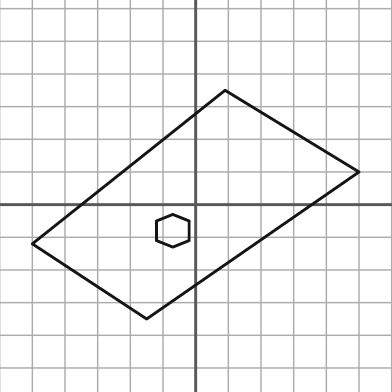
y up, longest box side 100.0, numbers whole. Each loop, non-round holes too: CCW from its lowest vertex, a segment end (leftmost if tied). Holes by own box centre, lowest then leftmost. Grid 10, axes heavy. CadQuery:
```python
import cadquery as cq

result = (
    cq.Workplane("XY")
    .moveTo(-15.0, -35.0)
    .lineTo(50.0, 10.0)
    .lineTo(9.0, 35.0)
    .lineTo(-50.0, -12.0)
    .close()
    .moveTo(-7.0, -13.0)
    .lineTo(-2.0, -11.0)
    .lineTo(-2.0, -5.0)
    .lineTo(-7.0, -3.0)
    .lineTo(-12.0, -5.0)
    .lineTo(-12.0, -11.0)
    .close()
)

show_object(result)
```